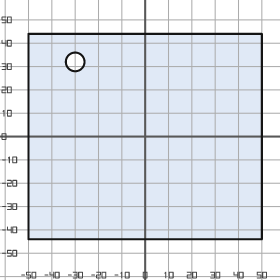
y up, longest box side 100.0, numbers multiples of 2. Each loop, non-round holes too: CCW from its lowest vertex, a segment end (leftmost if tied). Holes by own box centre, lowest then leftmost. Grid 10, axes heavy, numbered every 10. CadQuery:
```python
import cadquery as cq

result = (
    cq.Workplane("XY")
    .moveTo(-50.0, -44.0)
    .lineTo(50.0, -44.0)
    .lineTo(50.0, 44.0)
    .lineTo(-50.0, 44.0)
    .close()
    .moveTo(-30.0, 32.0)
    .circle(4.0)
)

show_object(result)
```